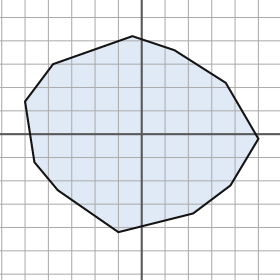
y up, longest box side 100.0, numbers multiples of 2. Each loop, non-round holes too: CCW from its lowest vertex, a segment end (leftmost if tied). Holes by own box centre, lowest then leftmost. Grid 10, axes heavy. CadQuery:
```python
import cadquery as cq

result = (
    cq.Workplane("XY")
    .moveTo(-10.0, -42.0)
    .lineTo(22.0, -34.0)
    .lineTo(38.0, -22.0)
    .lineTo(50.0, -2.0)
    .lineTo(36.0, 22.0)
    .lineTo(14.0, 36.0)
    .lineTo(-4.0, 42.0)
    .lineTo(-38.0, 30.0)
    .lineTo(-50.0, 14.0)
    .lineTo(-46.0, -12.0)
    .lineTo(-36.0, -24.0)
    .close()
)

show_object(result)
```